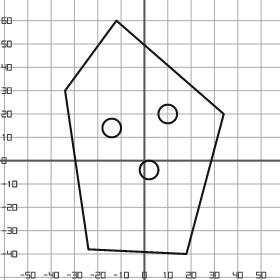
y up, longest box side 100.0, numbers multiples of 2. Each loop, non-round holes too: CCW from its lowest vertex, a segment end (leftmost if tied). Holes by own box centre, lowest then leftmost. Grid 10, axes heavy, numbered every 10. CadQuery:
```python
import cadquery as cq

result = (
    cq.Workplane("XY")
    .moveTo(18.0, -40.0)
    .lineTo(34.0, 20.0)
    .lineTo(-12.0, 60.0)
    .lineTo(-34.0, 30.0)
    .lineTo(-24.0, -38.0)
    .close()
    .moveTo(2.0, -4.0)
    .circle(4.0)
    .moveTo(-14.0, 14.0)
    .circle(4.0)
    .moveTo(10.0, 20.0)
    .circle(4.0)
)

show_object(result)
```